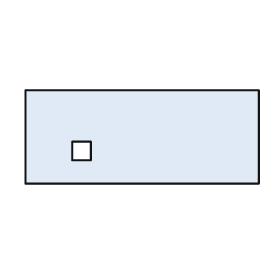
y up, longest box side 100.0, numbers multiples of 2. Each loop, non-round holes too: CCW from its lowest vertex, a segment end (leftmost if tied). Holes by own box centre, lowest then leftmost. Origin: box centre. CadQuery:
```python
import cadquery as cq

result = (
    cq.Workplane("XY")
    .moveTo(-50.0, -20.0)
    .lineTo(50.0, -20.0)
    .lineTo(50.0, 20.0)
    .lineTo(-50.0, 20.0)
    .close()
    .moveTo(-30.0, -10.0)
    .lineTo(-22.0, -10.0)
    .lineTo(-22.0, -2.0)
    .lineTo(-30.0, -2.0)
    .close()
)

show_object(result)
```